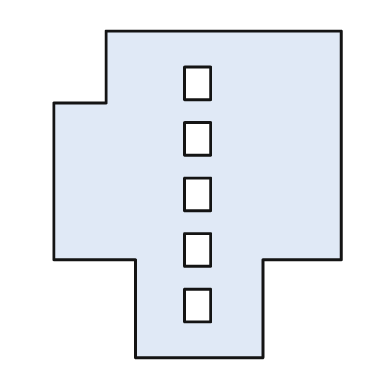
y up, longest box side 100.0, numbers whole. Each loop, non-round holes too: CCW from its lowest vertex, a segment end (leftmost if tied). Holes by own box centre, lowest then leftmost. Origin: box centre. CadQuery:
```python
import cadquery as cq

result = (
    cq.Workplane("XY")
    .moveTo(-19.0, -50.0)
    .lineTo(20.0, -50.0)
    .lineTo(20.0, -20.0)
    .lineTo(44.0, -20.0)
    .lineTo(44.0, 50.0)
    .lineTo(-28.0, 50.0)
    .lineTo(-28.0, 28.0)
    .lineTo(-44.0, 28.0)
    .lineTo(-44.0, -20.0)
    .lineTo(-19.0, -20.0)
    .close()
    .moveTo(-4.0, -39.0)
    .lineTo(4.0, -39.0)
    .lineTo(4.0, -29.0)
    .lineTo(-4.0, -29.0)
    .close()
    .moveTo(-4.0, -22.0)
    .lineTo(4.0, -22.0)
    .lineTo(4.0, -12.0)
    .lineTo(-4.0, -12.0)
    .close()
    .moveTo(-4.0, -5.0)
    .lineTo(4.0, -5.0)
    .lineTo(4.0, 5.0)
    .lineTo(-4.0, 5.0)
    .close()
    .moveTo(-4.0, 12.0)
    .lineTo(4.0, 12.0)
    .lineTo(4.0, 22.0)
    .lineTo(-4.0, 22.0)
    .close()
    .moveTo(-4.0, 29.0)
    .lineTo(4.0, 29.0)
    .lineTo(4.0, 39.0)
    .lineTo(-4.0, 39.0)
    .close()
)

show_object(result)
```